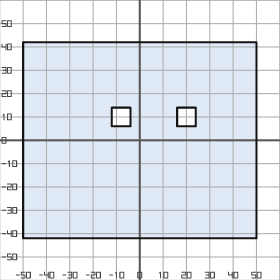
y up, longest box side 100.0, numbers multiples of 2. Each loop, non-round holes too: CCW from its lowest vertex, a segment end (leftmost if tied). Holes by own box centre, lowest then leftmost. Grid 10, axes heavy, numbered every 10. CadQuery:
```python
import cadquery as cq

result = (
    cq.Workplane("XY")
    .moveTo(-50.0, -42.0)
    .lineTo(50.0, -42.0)
    .lineTo(50.0, 42.0)
    .lineTo(-50.0, 42.0)
    .close()
    .moveTo(-12.0, 6.0)
    .lineTo(-4.0, 6.0)
    .lineTo(-4.0, 14.0)
    .lineTo(-12.0, 14.0)
    .close()
    .moveTo(16.0, 6.0)
    .lineTo(24.0, 6.0)
    .lineTo(24.0, 14.0)
    .lineTo(16.0, 14.0)
    .close()
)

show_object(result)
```